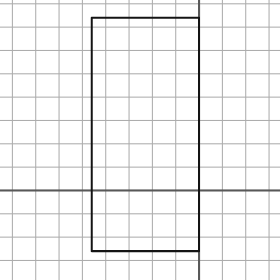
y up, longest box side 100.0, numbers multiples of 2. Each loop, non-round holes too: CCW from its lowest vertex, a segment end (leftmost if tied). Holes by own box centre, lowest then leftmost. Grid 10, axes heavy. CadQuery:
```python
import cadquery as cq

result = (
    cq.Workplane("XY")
    .moveTo(-46.0, -26.0)
    .lineTo(0.0, -26.0)
    .lineTo(0.0, 74.0)
    .lineTo(-46.0, 74.0)
    .close()
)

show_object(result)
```